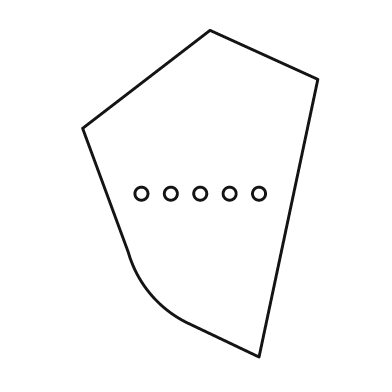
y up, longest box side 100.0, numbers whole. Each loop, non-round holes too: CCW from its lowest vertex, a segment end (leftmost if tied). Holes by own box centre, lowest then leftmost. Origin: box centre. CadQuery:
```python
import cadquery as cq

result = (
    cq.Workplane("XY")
    .moveTo(18.0, -50.0)
    .lineTo(36.0, 35.0)
    .lineTo(3.0, 50.0)
    .lineTo(-36.0, 20.0)
    .lineTo(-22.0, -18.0)
    .threePointArc((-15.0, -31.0), (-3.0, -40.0))
    .close()
    .moveTo(-18.0, 0.0)
    .circle(2.0)
    .moveTo(-9.0, 0.0)
    .circle(2.0)
    .moveTo(0.0, 0.0)
    .circle(2.0)
    .moveTo(9.0, 0.0)
    .circle(2.0)
    .moveTo(18.0, 0.0)
    .circle(2.0)
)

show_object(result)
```